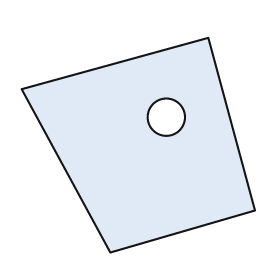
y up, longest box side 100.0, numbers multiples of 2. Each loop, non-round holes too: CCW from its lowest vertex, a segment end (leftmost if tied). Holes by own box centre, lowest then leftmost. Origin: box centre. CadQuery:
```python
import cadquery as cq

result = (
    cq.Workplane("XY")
    .moveTo(-12.0, -46.0)
    .lineTo(50.0, -28.0)
    .lineTo(30.0, 46.0)
    .lineTo(-50.0, 24.0)
    .close()
    .moveTo(12.0, 12.0)
    .circle(8.0)
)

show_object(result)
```